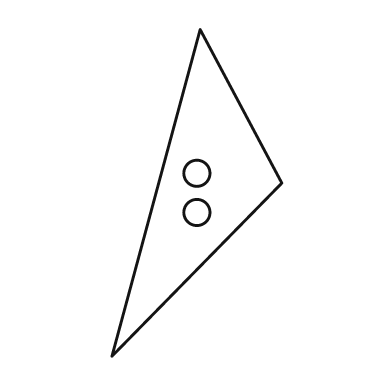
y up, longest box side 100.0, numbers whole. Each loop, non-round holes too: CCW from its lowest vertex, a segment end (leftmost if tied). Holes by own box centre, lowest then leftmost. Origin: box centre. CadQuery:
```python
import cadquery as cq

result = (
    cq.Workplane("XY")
    .moveTo(-26.0, -50.0)
    .lineTo(26.0, 3.0)
    .lineTo(1.0, 50.0)
    .close()
    .moveTo(0.0, -6.0)
    .circle(4.0)
    .moveTo(0.0, 6.0)
    .circle(4.0)
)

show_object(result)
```